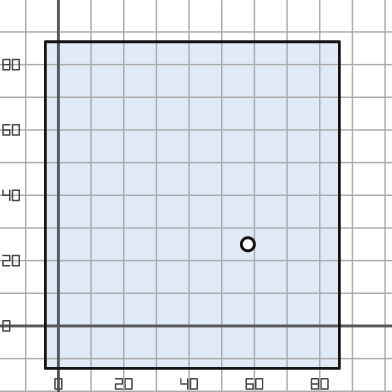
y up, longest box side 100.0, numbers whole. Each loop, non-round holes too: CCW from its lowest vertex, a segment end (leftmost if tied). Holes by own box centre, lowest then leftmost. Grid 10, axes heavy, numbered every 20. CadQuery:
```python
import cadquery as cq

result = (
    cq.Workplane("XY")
    .moveTo(-4.0, -13.0)
    .lineTo(86.0, -13.0)
    .lineTo(86.0, 87.0)
    .lineTo(-4.0, 87.0)
    .close()
    .moveTo(58.0, 25.0)
    .circle(2.0)
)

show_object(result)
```